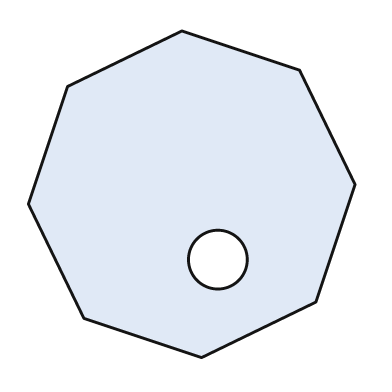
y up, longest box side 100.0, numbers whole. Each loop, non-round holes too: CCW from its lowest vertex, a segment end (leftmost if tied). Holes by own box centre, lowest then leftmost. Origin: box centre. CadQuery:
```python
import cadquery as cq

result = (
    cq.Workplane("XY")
    .moveTo(3.0, -50.0)
    .lineTo(38.0, -33.0)
    .lineTo(50.0, 3.0)
    .lineTo(33.0, 38.0)
    .lineTo(-3.0, 50.0)
    .lineTo(-38.0, 33.0)
    .lineTo(-50.0, -3.0)
    .lineTo(-33.0, -38.0)
    .close()
    .moveTo(8.0, -20.0)
    .circle(9.0)
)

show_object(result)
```